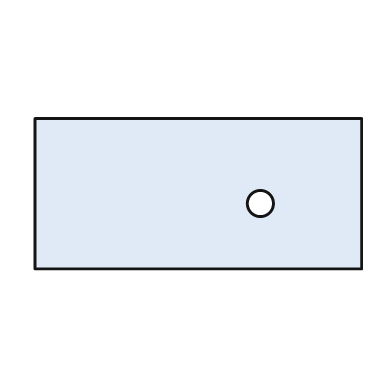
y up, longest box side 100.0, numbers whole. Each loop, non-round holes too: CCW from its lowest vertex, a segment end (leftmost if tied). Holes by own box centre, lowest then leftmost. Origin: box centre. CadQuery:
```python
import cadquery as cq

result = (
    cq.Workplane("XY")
    .moveTo(-50.0, -23.0)
    .lineTo(50.0, -23.0)
    .lineTo(50.0, 23.0)
    .lineTo(-50.0, 23.0)
    .close()
    .moveTo(19.0, -3.0)
    .circle(4.0)
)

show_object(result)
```